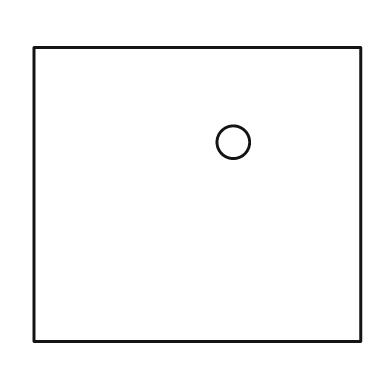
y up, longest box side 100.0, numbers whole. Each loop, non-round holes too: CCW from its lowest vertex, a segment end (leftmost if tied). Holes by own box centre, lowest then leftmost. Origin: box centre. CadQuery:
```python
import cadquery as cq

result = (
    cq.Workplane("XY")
    .moveTo(-50.0, -45.0)
    .lineTo(50.0, -45.0)
    .lineTo(50.0, 45.0)
    .lineTo(-50.0, 45.0)
    .close()
    .moveTo(11.0, 16.0)
    .circle(5.0)
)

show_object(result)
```